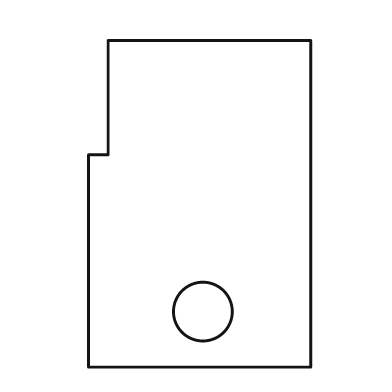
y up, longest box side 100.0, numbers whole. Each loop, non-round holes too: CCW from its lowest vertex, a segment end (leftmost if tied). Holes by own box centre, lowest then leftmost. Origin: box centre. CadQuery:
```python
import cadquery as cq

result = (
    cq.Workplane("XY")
    .moveTo(-34.0, -50.0)
    .lineTo(34.0, -50.0)
    .lineTo(34.0, 50.0)
    .lineTo(-28.0, 50.0)
    .lineTo(-28.0, 15.0)
    .lineTo(-34.0, 15.0)
    .close()
    .moveTo(1.0, -33.0)
    .circle(9.0)
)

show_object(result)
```